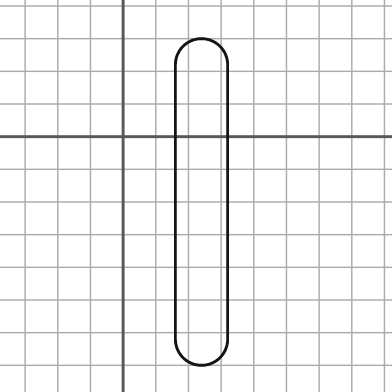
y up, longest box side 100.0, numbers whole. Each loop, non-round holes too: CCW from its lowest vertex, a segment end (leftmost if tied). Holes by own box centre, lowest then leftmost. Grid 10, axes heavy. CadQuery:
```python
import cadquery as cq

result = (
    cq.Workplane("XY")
    .moveTo(16.0, -62.0)
    .threePointArc((24.0, -70.0), (32.0, -62.0))
    .lineTo(32.0, 22.0)
    .threePointArc((24.0, 30.0), (16.0, 22.0))
    .close()
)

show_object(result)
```